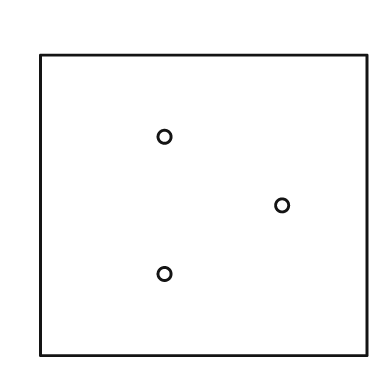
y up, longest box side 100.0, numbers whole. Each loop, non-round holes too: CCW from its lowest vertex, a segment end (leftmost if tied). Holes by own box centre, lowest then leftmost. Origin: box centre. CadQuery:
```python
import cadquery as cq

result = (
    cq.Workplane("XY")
    .moveTo(-50.0, -46.0)
    .lineTo(50.0, -46.0)
    .lineTo(50.0, 46.0)
    .lineTo(-50.0, 46.0)
    .close()
    .moveTo(-12.0, -21.0)
    .circle(2.0)
    .moveTo(24.0, 0.0)
    .circle(2.0)
    .moveTo(-12.0, 21.0)
    .circle(2.0)
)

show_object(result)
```